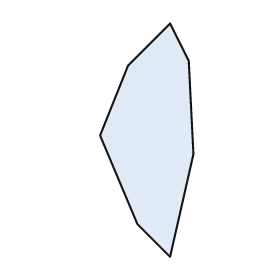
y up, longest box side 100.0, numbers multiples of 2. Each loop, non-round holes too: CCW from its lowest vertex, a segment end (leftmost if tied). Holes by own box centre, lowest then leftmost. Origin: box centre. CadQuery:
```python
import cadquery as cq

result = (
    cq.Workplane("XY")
    .moveTo(10.0, -50.0)
    .lineTo(20.0, -6.0)
    .lineTo(18.0, 34.0)
    .lineTo(10.0, 50.0)
    .lineTo(-8.0, 32.0)
    .lineTo(-20.0, 2.0)
    .lineTo(-4.0, -36.0)
    .close()
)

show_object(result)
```